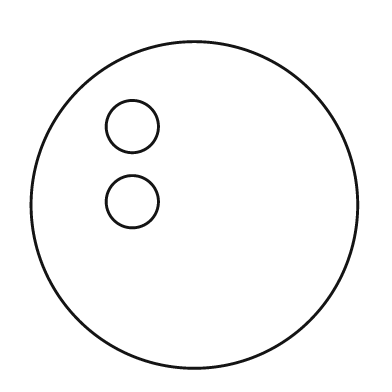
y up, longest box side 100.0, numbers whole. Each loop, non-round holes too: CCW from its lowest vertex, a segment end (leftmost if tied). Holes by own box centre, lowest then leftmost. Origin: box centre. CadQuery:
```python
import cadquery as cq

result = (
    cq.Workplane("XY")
    .moveTo(0.0, 0.0)
    .circle(50.0)
    .moveTo(-19.0, 1.0)
    .circle(8.0)
    .moveTo(-19.0, 24.0)
    .circle(8.0)
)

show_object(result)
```